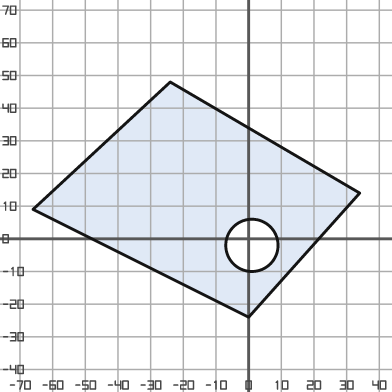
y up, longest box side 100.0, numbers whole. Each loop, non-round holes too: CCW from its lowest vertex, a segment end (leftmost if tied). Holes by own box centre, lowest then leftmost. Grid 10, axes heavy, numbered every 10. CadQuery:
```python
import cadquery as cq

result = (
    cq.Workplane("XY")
    .moveTo(0.0, -24.0)
    .lineTo(34.0, 14.0)
    .lineTo(-24.0, 48.0)
    .lineTo(-66.0, 9.0)
    .close()
    .moveTo(1.0, -2.0)
    .circle(8.0)
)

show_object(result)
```